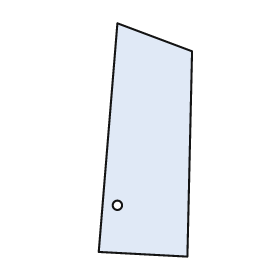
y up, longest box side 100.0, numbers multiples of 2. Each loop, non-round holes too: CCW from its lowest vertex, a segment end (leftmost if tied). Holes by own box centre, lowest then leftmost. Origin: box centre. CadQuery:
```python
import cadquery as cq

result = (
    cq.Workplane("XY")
    .moveTo(18.0, -50.0)
    .lineTo(20.0, 38.0)
    .lineTo(-12.0, 50.0)
    .lineTo(-20.0, -48.0)
    .close()
    .moveTo(-12.0, -28.0)
    .circle(2.0)
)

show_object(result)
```